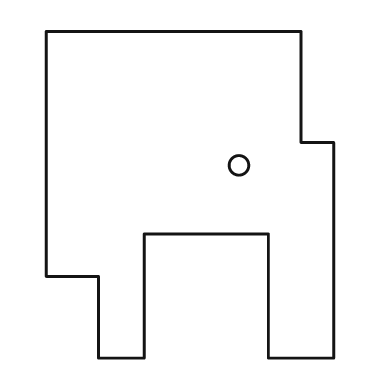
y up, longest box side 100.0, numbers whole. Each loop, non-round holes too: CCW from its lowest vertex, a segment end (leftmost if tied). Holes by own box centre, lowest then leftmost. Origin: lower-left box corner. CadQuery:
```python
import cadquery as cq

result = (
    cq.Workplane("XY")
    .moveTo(16.0, 0.0)
    .lineTo(30.0, 0.0)
    .lineTo(30.0, 38.0)
    .lineTo(68.0, 38.0)
    .lineTo(68.0, 0.0)
    .lineTo(88.0, 0.0)
    .lineTo(88.0, 66.0)
    .lineTo(78.0, 66.0)
    .lineTo(78.0, 100.0)
    .lineTo(0.0, 100.0)
    .lineTo(0.0, 25.0)
    .lineTo(16.0, 25.0)
    .close()
    .moveTo(59.0, 59.0)
    .circle(3.0)
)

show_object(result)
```